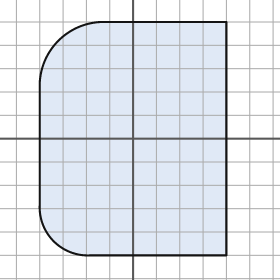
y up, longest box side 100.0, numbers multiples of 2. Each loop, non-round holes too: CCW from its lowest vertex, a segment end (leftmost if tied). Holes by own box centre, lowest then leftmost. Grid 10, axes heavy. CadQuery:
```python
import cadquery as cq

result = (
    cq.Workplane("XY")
    .moveTo(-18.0, -50.0)
    .lineTo(40.0, -50.0)
    .lineTo(40.0, 50.0)
    .lineTo(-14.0, 50.0)
    .threePointArc((-32.0, 42.0), (-40.0, 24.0))
    .lineTo(-40.0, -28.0)
    .threePointArc((-34.0, -44.0), (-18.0, -50.0))
    .close()
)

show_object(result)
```